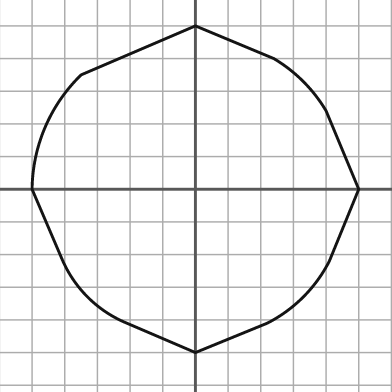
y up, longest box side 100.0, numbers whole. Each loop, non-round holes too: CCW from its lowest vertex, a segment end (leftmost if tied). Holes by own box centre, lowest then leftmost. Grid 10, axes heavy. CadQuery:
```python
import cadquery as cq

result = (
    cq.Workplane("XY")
    .moveTo(0.0, -50.0)
    .lineTo(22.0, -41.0)
    .threePointArc((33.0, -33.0), (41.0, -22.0))
    .lineTo(50.0, 0.0)
    .lineTo(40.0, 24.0)
    .threePointArc((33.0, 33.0), (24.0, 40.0))
    .lineTo(0.0, 50.0)
    .lineTo(-35.0, 35.0)
    .threePointArc((-46.0, 19.0), (-50.0, 0.0))
    .lineTo(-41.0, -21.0)
    .threePointArc((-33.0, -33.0), (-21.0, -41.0))
    .close()
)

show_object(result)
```